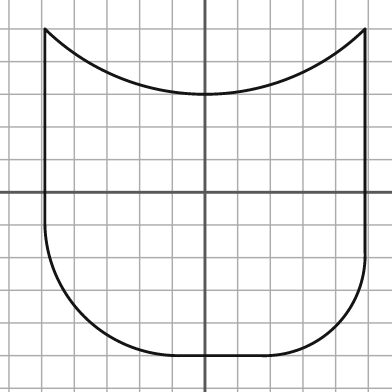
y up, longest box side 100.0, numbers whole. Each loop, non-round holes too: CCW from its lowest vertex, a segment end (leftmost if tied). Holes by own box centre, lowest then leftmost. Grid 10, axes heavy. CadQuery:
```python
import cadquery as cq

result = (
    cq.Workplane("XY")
    .moveTo(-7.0, -50.0)
    .lineTo(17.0, -50.0)
    .threePointArc((40.0, -41.0), (49.0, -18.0))
    .lineTo(49.0, 50.0)
    .threePointArc((0.0, 30.0), (-49.0, 50.0))
    .lineTo(-49.0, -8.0)
    .threePointArc((-37.0, -38.0), (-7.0, -50.0))
    .close()
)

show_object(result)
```